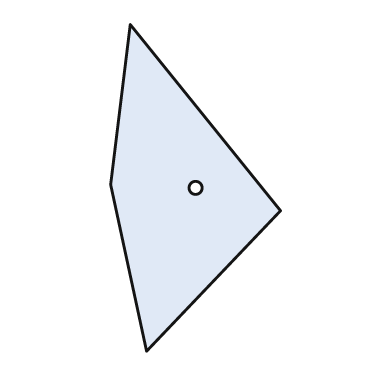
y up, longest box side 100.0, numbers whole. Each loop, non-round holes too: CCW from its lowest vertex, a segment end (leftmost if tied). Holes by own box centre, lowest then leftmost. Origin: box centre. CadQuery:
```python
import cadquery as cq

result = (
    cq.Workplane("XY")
    .moveTo(-15.0, -50.0)
    .lineTo(26.0, -7.0)
    .lineTo(-20.0, 50.0)
    .lineTo(-26.0, 1.0)
    .close()
    .moveTo(0.0, 0.0)
    .circle(2.0)
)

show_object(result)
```